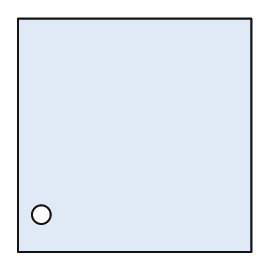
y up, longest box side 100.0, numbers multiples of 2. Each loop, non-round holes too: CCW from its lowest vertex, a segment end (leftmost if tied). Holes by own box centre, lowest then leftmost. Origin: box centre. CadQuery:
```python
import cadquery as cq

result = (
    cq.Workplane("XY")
    .moveTo(-50.0, -50.0)
    .lineTo(50.0, -50.0)
    .lineTo(50.0, 50.0)
    .lineTo(-50.0, 50.0)
    .close()
    .moveTo(-40.0, -34.0)
    .circle(4.0)
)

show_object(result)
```